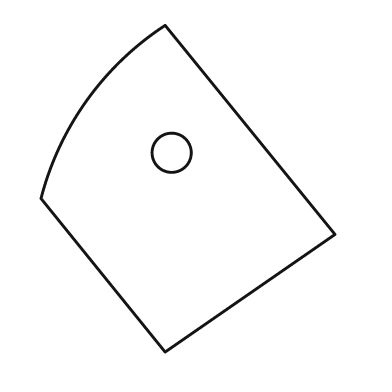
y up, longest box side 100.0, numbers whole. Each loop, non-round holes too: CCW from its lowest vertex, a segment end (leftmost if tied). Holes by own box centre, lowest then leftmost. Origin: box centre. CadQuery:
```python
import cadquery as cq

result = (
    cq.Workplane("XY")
    .moveTo(-7.0, -50.0)
    .lineTo(45.0, -14.0)
    .lineTo(-7.0, 50.0)
    .threePointArc((-31.0, 27.0), (-45.0, -3.0))
    .close()
    .moveTo(-5.0, 11.0)
    .circle(6.0)
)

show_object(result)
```